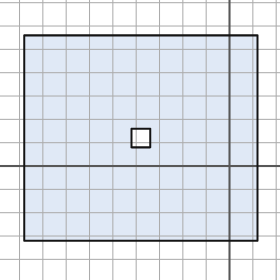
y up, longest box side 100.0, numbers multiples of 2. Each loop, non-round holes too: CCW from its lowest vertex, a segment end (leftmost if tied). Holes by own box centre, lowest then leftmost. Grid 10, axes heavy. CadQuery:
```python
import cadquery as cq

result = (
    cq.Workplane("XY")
    .moveTo(-88.0, -32.0)
    .lineTo(12.0, -32.0)
    .lineTo(12.0, 56.0)
    .lineTo(-88.0, 56.0)
    .close()
    .moveTo(-42.0, 8.0)
    .lineTo(-34.0, 8.0)
    .lineTo(-34.0, 16.0)
    .lineTo(-42.0, 16.0)
    .close()
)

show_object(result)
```